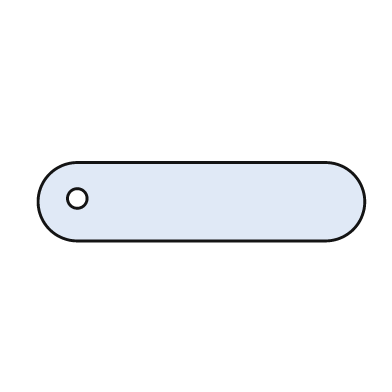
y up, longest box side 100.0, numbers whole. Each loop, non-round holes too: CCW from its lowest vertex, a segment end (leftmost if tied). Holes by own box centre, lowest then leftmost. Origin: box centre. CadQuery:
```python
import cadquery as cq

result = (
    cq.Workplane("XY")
    .moveTo(-38.0, -12.0)
    .lineTo(38.0, -12.0)
    .threePointArc((50.0, 0.0), (38.0, 12.0))
    .lineTo(-38.0, 12.0)
    .threePointArc((-50.0, 0.0), (-38.0, -12.0))
    .close()
    .moveTo(-38.0, 1.0)
    .circle(3.0)
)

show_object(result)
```